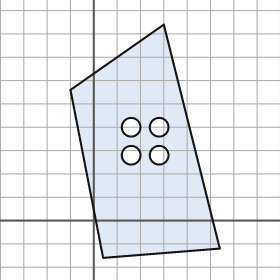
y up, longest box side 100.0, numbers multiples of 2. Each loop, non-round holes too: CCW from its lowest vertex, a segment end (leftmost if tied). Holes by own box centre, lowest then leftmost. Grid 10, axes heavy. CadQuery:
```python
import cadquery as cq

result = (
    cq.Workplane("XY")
    .moveTo(4.0, -16.0)
    .lineTo(54.0, -12.0)
    .lineTo(30.0, 84.0)
    .lineTo(-10.0, 56.0)
    .close()
    .moveTo(16.0, 28.0)
    .circle(4.0)
    .moveTo(28.0, 28.0)
    .circle(4.0)
    .moveTo(16.0, 40.0)
    .circle(4.0)
    .moveTo(28.0, 40.0)
    .circle(4.0)
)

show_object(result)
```